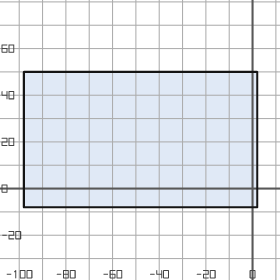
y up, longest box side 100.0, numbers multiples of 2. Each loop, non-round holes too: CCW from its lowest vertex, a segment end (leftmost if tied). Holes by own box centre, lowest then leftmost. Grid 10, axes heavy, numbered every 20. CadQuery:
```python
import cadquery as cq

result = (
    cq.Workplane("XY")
    .moveTo(-98.0, -8.0)
    .lineTo(2.0, -8.0)
    .lineTo(2.0, 50.0)
    .lineTo(-98.0, 50.0)
    .close()
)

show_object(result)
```